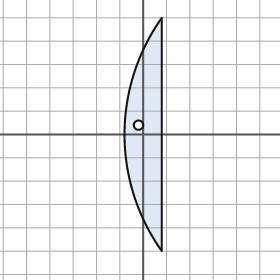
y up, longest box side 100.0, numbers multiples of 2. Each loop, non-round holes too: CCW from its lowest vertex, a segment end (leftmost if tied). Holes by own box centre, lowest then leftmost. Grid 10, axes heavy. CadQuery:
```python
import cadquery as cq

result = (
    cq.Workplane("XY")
    .moveTo(8.0, -50.0)
    .lineTo(8.0, 50.0)
    .threePointArc((-8.0, 0.0), (8.0, -50.0))
    .close()
    .moveTo(-2.0, 4.0)
    .circle(2.0)
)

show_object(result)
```